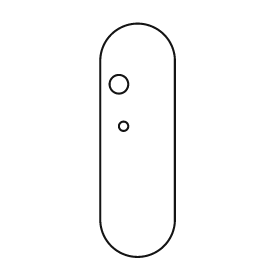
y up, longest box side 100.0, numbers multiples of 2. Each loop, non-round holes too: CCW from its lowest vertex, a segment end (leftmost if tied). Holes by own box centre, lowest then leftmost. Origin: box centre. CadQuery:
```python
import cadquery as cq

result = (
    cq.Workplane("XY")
    .moveTo(-16.0, -34.0)
    .threePointArc((0.0, -50.0), (16.0, -34.0))
    .lineTo(16.0, 34.0)
    .threePointArc((0.0, 50.0), (-16.0, 34.0))
    .close()
    .moveTo(-6.0, 6.0)
    .circle(2.0)
    .moveTo(-8.0, 24.0)
    .circle(4.0)
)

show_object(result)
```